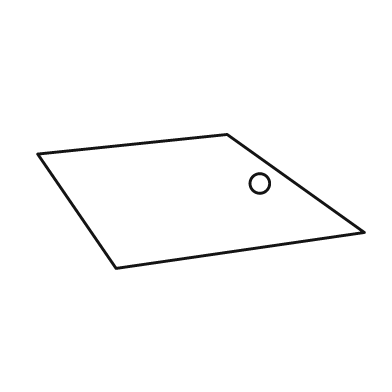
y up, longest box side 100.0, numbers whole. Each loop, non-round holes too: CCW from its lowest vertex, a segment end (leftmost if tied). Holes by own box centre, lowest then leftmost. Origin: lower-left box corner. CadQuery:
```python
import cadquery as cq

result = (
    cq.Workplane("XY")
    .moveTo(24.0, 0.0)
    .lineTo(100.0, 11.0)
    .lineTo(58.0, 41.0)
    .lineTo(0.0, 35.0)
    .close()
    .moveTo(68.0, 26.0)
    .circle(3.0)
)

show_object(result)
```